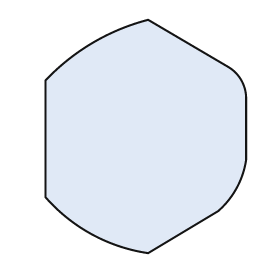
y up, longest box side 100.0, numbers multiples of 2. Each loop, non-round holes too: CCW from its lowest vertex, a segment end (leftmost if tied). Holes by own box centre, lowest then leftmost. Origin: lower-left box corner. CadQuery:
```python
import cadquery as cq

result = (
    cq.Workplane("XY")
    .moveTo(44.0, 0.0)
    .lineTo(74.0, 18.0)
    .threePointArc((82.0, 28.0), (86.0, 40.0))
    .lineTo(86.0, 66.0)
    .threePointArc((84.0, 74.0), (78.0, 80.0))
    .lineTo(44.0, 100.0)
    .threePointArc((20.0, 90.0), (0.0, 74.0))
    .lineTo(0.0, 24.0)
    .threePointArc((20.0, 8.0), (44.0, 0.0))
    .close()
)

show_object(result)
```